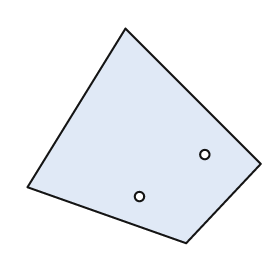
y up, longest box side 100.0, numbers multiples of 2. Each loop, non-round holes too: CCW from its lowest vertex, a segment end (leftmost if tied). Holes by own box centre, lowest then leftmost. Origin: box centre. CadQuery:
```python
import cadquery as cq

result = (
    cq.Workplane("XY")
    .moveTo(18.0, -46.0)
    .lineTo(50.0, -12.0)
    .lineTo(-8.0, 46.0)
    .lineTo(-50.0, -22.0)
    .close()
    .moveTo(-2.0, -26.0)
    .circle(2.0)
    .moveTo(26.0, -8.0)
    .circle(2.0)
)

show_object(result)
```